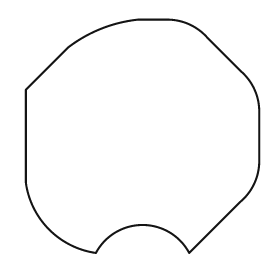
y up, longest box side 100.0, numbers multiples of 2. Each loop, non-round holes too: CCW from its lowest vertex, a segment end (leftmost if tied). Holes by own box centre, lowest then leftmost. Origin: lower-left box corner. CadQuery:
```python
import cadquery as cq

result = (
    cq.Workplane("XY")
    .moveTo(30.0, 0.0)
    .threePointArc((50.0, 12.0), (70.0, 0.0))
    .lineTo(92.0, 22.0)
    .threePointArc((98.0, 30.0), (100.0, 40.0))
    .lineTo(100.0, 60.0)
    .threePointArc((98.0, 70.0), (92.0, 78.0))
    .lineTo(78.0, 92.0)
    .threePointArc((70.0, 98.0), (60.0, 100.0))
    .lineTo(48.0, 100.0)
    .threePointArc((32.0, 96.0), (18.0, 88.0))
    .lineTo(0.0, 70.0)
    .lineTo(0.0, 30.0)
    .threePointArc((10.0, 10.0), (30.0, 0.0))
    .close()
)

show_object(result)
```